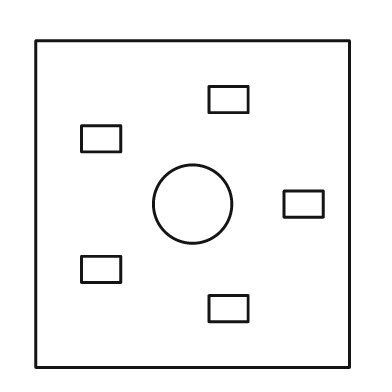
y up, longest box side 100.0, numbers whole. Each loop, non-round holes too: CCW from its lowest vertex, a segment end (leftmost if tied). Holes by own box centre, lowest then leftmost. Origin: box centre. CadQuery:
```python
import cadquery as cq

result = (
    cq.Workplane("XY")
    .moveTo(-48.0, -50.0)
    .lineTo(48.0, -50.0)
    .lineTo(48.0, 50.0)
    .lineTo(-48.0, 50.0)
    .close()
    .moveTo(5.0, -36.0)
    .lineTo(17.0, -36.0)
    .lineTo(17.0, -28.0)
    .lineTo(5.0, -28.0)
    .close()
    .moveTo(-34.0, -24.0)
    .lineTo(-22.0, -24.0)
    .lineTo(-22.0, -16.0)
    .lineTo(-34.0, -16.0)
    .close()
    .moveTo(0.0, 0.0)
    .circle(12.0)
    .moveTo(28.0, -4.0)
    .lineTo(40.0, -4.0)
    .lineTo(40.0, 4.0)
    .lineTo(28.0, 4.0)
    .close()
    .moveTo(-34.0, 16.0)
    .lineTo(-22.0, 16.0)
    .lineTo(-22.0, 24.0)
    .lineTo(-34.0, 24.0)
    .close()
    .moveTo(5.0, 28.0)
    .lineTo(17.0, 28.0)
    .lineTo(17.0, 36.0)
    .lineTo(5.0, 36.0)
    .close()
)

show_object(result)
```